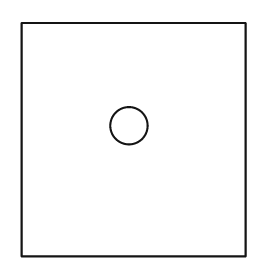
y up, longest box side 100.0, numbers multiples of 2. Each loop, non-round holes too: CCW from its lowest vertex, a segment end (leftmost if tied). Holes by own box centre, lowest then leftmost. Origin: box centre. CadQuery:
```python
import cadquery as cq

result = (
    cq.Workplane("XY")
    .moveTo(-48.0, -50.0)
    .lineTo(48.0, -50.0)
    .lineTo(48.0, 50.0)
    .lineTo(-48.0, 50.0)
    .close()
    .moveTo(-2.0, 6.0)
    .circle(8.0)
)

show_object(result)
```